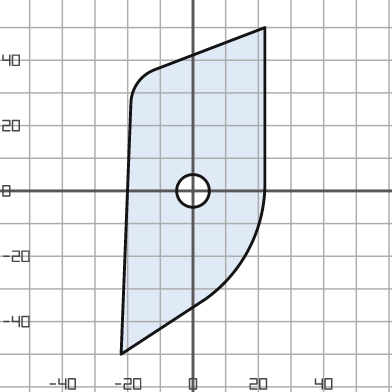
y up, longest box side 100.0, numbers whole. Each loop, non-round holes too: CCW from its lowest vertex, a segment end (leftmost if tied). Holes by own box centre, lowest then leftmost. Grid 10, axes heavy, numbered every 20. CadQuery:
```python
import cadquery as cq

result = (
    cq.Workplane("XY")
    .moveTo(-22.0, -50.0)
    .lineTo(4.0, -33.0)
    .threePointArc((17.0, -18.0), (22.0, 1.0))
    .lineTo(22.0, 50.0)
    .lineTo(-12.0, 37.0)
    .threePointArc((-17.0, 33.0), (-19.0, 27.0))
    .close()
    .moveTo(0.0, 0.0)
    .circle(5.0)
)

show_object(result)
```